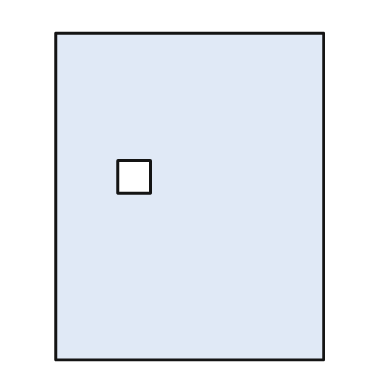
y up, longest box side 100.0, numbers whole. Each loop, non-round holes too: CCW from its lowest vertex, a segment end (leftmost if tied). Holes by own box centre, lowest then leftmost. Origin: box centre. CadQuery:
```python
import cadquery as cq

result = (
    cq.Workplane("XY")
    .moveTo(-41.0, -50.0)
    .lineTo(41.0, -50.0)
    .lineTo(41.0, 50.0)
    .lineTo(-41.0, 50.0)
    .close()
    .moveTo(-22.0, 1.0)
    .lineTo(-12.0, 1.0)
    .lineTo(-12.0, 11.0)
    .lineTo(-22.0, 11.0)
    .close()
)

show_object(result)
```